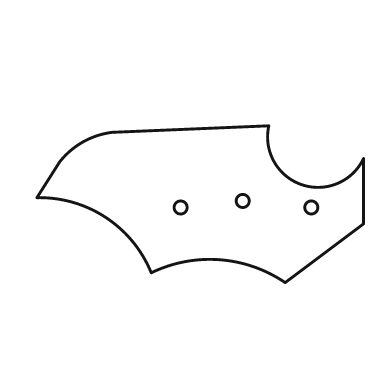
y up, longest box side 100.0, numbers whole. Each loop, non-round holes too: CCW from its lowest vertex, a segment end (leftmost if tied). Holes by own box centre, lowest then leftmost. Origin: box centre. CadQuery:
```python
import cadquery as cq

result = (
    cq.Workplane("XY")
    .moveTo(26.0, -24.0)
    .lineTo(50.0, -6.0)
    .lineTo(50.0, 14.0)
    .threePointArc((31.0, 6.0), (21.0, 24.0))
    .lineTo(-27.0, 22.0)
    .threePointArc((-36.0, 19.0), (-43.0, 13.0))
    .lineTo(-50.0, 2.0)
    .threePointArc((-29.0, -4.0), (-15.0, -21.0))
    .threePointArc((6.0, -17.0), (26.0, -24.0))
    .close()
    .moveTo(-6.0, -1.0)
    .circle(2.0)
    .moveTo(34.0, -1.0)
    .circle(2.0)
    .moveTo(13.0, 1.0)
    .circle(2.0)
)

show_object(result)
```